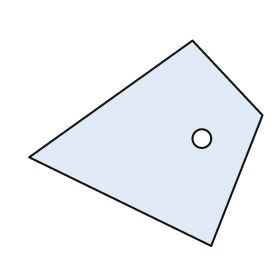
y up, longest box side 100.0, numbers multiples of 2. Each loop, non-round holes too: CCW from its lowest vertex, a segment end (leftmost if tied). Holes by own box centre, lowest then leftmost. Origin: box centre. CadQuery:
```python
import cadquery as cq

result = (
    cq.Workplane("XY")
    .moveTo(28.0, -44.0)
    .lineTo(50.0, 12.0)
    .lineTo(20.0, 44.0)
    .lineTo(-50.0, -6.0)
    .close()
    .moveTo(24.0, 2.0)
    .circle(4.0)
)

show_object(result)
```